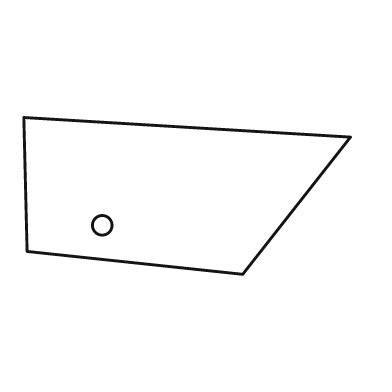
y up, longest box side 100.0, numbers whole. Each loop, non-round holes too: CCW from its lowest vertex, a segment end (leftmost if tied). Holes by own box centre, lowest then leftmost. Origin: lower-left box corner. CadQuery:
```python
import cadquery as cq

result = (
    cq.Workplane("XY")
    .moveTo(67.0, 0.0)
    .lineTo(100.0, 42.0)
    .lineTo(0.0, 48.0)
    .lineTo(1.0, 7.0)
    .close()
    .moveTo(24.0, 15.0)
    .circle(3.0)
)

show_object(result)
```